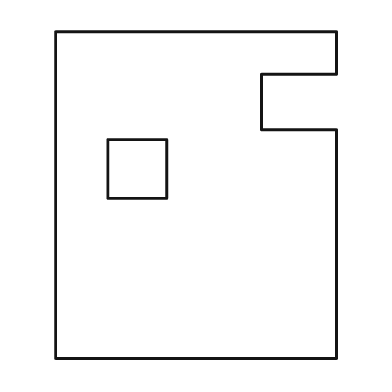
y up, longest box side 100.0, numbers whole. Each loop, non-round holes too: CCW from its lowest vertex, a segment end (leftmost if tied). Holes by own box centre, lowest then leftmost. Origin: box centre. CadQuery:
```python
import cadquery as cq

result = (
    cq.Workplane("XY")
    .moveTo(-43.0, -50.0)
    .lineTo(43.0, -50.0)
    .lineTo(43.0, 20.0)
    .lineTo(20.0, 20.0)
    .lineTo(20.0, 37.0)
    .lineTo(43.0, 37.0)
    .lineTo(43.0, 50.0)
    .lineTo(-43.0, 50.0)
    .close()
    .moveTo(-27.0, -1.0)
    .lineTo(-9.0, -1.0)
    .lineTo(-9.0, 17.0)
    .lineTo(-27.0, 17.0)
    .close()
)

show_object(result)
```